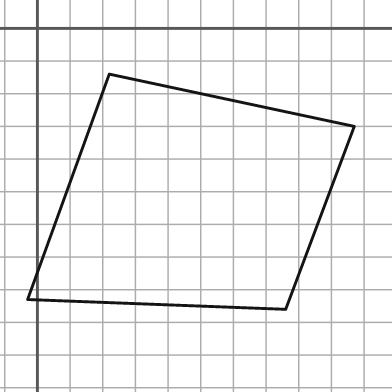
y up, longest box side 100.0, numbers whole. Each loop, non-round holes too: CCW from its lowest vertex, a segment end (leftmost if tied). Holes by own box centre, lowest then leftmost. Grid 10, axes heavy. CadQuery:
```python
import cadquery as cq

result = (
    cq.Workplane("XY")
    .moveTo(76.0, -86.0)
    .lineTo(97.0, -30.0)
    .lineTo(22.0, -14.0)
    .lineTo(-3.0, -83.0)
    .close()
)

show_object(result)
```